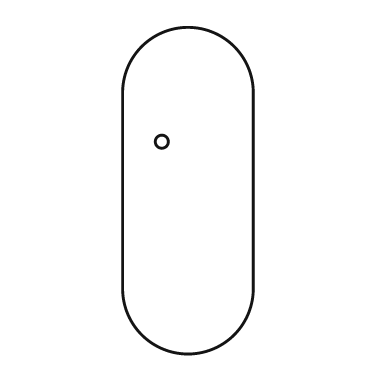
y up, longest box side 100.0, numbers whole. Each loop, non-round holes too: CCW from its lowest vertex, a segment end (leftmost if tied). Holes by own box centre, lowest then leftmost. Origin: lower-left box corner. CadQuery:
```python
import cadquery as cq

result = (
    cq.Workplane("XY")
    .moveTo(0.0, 20.0)
    .threePointArc((20.0, 0.0), (40.0, 20.0))
    .lineTo(40.0, 80.0)
    .threePointArc((20.0, 100.0), (0.0, 80.0))
    .close()
    .moveTo(12.0, 65.0)
    .circle(2.0)
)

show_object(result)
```